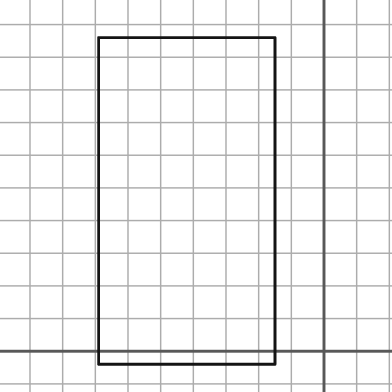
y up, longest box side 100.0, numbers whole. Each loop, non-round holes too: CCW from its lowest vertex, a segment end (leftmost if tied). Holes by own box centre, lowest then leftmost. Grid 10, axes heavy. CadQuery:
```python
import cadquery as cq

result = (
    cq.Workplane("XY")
    .moveTo(-69.0, -4.0)
    .lineTo(-15.0, -4.0)
    .lineTo(-15.0, 96.0)
    .lineTo(-69.0, 96.0)
    .close()
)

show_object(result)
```